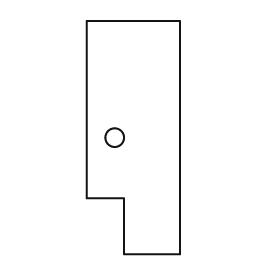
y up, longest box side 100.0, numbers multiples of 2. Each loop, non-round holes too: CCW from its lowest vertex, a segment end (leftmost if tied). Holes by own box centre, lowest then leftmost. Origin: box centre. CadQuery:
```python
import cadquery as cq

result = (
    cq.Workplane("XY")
    .moveTo(-4.0, -50.0)
    .lineTo(20.0, -50.0)
    .lineTo(20.0, 50.0)
    .lineTo(-20.0, 50.0)
    .lineTo(-20.0, -26.0)
    .lineTo(-4.0, -26.0)
    .close()
    .moveTo(-8.0, 0.0)
    .circle(4.0)
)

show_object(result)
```